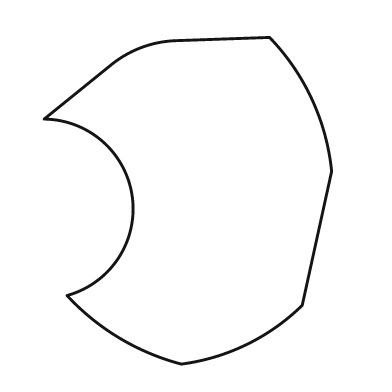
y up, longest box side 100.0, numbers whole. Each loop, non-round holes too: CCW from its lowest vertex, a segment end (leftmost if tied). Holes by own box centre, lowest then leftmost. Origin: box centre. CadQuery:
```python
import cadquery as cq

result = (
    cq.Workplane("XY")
    .moveTo(-2.0, -50.0)
    .threePointArc((18.0, -44.0), (35.0, -32.0))
    .lineTo(44.0, 9.0)
    .threePointArc((38.0, 31.0), (25.0, 50.0))
    .lineTo(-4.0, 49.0)
    .threePointArc((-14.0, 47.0), (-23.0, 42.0))
    .lineTo(-44.0, 25.0)
    .threePointArc((-17.0, 1.0), (-37.0, -29.0))
    .threePointArc((-21.0, -42.0), (-2.0, -50.0))
    .close()
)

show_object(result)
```